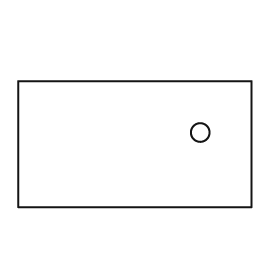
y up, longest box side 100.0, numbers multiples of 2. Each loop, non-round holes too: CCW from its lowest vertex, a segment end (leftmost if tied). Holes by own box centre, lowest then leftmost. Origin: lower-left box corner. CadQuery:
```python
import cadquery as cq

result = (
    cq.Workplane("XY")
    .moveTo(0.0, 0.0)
    .lineTo(100.0, 0.0)
    .lineTo(100.0, 54.0)
    .lineTo(0.0, 54.0)
    .close()
    .moveTo(78.0, 32.0)
    .circle(4.0)
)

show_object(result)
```